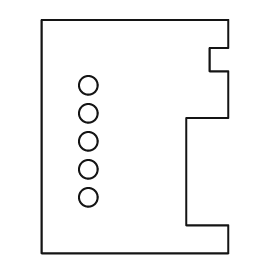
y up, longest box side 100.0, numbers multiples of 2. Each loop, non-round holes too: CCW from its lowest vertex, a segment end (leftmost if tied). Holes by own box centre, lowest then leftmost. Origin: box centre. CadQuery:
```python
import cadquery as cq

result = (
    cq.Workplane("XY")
    .moveTo(-40.0, -50.0)
    .lineTo(40.0, -50.0)
    .lineTo(40.0, -38.0)
    .lineTo(22.0, -38.0)
    .lineTo(22.0, 8.0)
    .lineTo(40.0, 8.0)
    .lineTo(40.0, 28.0)
    .lineTo(32.0, 28.0)
    .lineTo(32.0, 38.0)
    .lineTo(40.0, 38.0)
    .lineTo(40.0, 50.0)
    .lineTo(-40.0, 50.0)
    .close()
    .moveTo(-20.0, -26.0)
    .circle(4.0)
    .moveTo(-20.0, -14.0)
    .circle(4.0)
    .moveTo(-20.0, -2.0)
    .circle(4.0)
    .moveTo(-20.0, 10.0)
    .circle(4.0)
    .moveTo(-20.0, 22.0)
    .circle(4.0)
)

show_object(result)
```